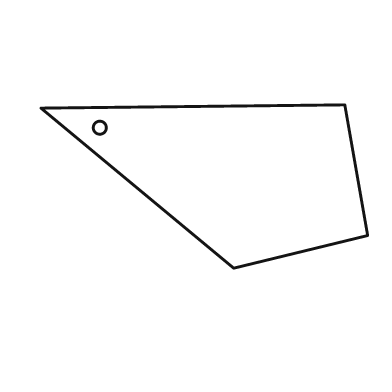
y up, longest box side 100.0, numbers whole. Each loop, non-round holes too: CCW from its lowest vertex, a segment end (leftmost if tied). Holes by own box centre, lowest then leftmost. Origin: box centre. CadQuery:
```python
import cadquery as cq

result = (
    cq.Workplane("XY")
    .moveTo(9.0, -25.0)
    .lineTo(50.0, -15.0)
    .lineTo(43.0, 25.0)
    .lineTo(-50.0, 24.0)
    .close()
    .moveTo(-32.0, 18.0)
    .circle(2.0)
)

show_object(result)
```